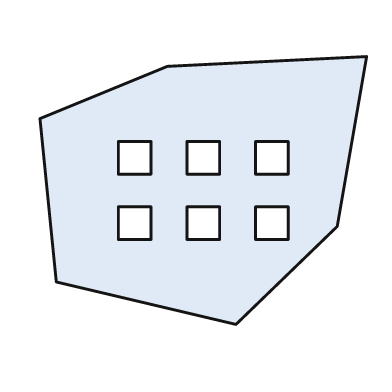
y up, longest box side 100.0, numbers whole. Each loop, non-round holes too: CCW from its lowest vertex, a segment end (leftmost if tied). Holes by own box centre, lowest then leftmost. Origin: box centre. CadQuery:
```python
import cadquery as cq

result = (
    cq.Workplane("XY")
    .moveTo(10.0, -41.0)
    .lineTo(41.0, -11.0)
    .lineTo(50.0, 41.0)
    .lineTo(-11.0, 38.0)
    .lineTo(-50.0, 22.0)
    .lineTo(-45.0, -28.0)
    .close()
    .moveTo(-26.0, -15.0)
    .lineTo(-16.0, -15.0)
    .lineTo(-16.0, -5.0)
    .lineTo(-26.0, -5.0)
    .close()
    .moveTo(-5.0, -15.0)
    .lineTo(5.0, -15.0)
    .lineTo(5.0, -5.0)
    .lineTo(-5.0, -5.0)
    .close()
    .moveTo(16.0, -15.0)
    .lineTo(26.0, -15.0)
    .lineTo(26.0, -5.0)
    .lineTo(16.0, -5.0)
    .close()
    .moveTo(-26.0, 5.0)
    .lineTo(-16.0, 5.0)
    .lineTo(-16.0, 15.0)
    .lineTo(-26.0, 15.0)
    .close()
    .moveTo(-5.0, 5.0)
    .lineTo(5.0, 5.0)
    .lineTo(5.0, 15.0)
    .lineTo(-5.0, 15.0)
    .close()
    .moveTo(16.0, 5.0)
    .lineTo(26.0, 5.0)
    .lineTo(26.0, 15.0)
    .lineTo(16.0, 15.0)
    .close()
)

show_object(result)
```